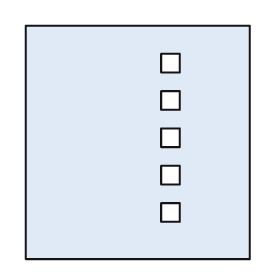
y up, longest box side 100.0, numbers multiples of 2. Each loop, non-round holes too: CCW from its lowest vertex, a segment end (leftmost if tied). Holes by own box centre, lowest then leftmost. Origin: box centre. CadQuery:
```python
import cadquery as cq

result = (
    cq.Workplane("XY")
    .moveTo(-48.0, -50.0)
    .lineTo(48.0, -50.0)
    .lineTo(48.0, 50.0)
    .lineTo(-48.0, 50.0)
    .close()
    .moveTo(10.0, -34.0)
    .lineTo(18.0, -34.0)
    .lineTo(18.0, -26.0)
    .lineTo(10.0, -26.0)
    .close()
    .moveTo(10.0, -18.0)
    .lineTo(18.0, -18.0)
    .lineTo(18.0, -10.0)
    .lineTo(10.0, -10.0)
    .close()
    .moveTo(10.0, -2.0)
    .lineTo(18.0, -2.0)
    .lineTo(18.0, 6.0)
    .lineTo(10.0, 6.0)
    .close()
    .moveTo(10.0, 14.0)
    .lineTo(18.0, 14.0)
    .lineTo(18.0, 22.0)
    .lineTo(10.0, 22.0)
    .close()
    .moveTo(10.0, 30.0)
    .lineTo(18.0, 30.0)
    .lineTo(18.0, 38.0)
    .lineTo(10.0, 38.0)
    .close()
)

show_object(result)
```